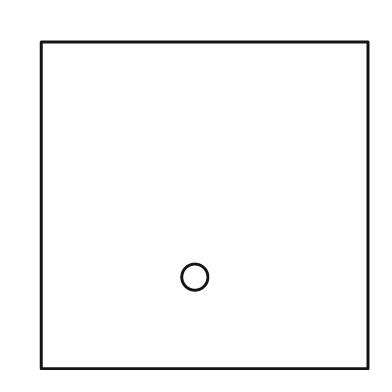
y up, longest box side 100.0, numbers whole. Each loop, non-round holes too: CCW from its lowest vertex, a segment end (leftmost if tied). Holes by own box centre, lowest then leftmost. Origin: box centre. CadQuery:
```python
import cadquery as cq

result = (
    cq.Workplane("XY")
    .moveTo(-50.0, -50.0)
    .lineTo(50.0, -50.0)
    .lineTo(50.0, 50.0)
    .lineTo(-50.0, 50.0)
    .close()
    .moveTo(-3.0, -22.0)
    .circle(4.0)
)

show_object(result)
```